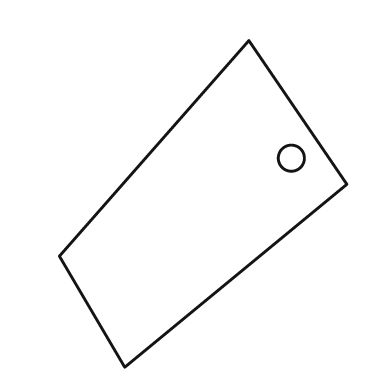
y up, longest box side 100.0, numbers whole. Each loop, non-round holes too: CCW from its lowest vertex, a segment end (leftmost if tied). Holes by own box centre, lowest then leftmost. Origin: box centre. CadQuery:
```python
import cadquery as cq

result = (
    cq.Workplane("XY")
    .moveTo(-24.0, -50.0)
    .lineTo(44.0, 6.0)
    .lineTo(14.0, 50.0)
    .lineTo(-44.0, -16.0)
    .close()
    .moveTo(27.0, 14.0)
    .circle(4.0)
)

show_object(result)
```